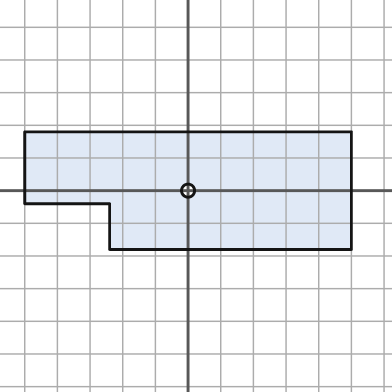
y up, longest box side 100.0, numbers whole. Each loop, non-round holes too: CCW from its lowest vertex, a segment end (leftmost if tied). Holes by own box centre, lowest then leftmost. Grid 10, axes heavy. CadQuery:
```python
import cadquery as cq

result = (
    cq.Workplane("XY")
    .moveTo(-24.0, -18.0)
    .lineTo(50.0, -18.0)
    .lineTo(50.0, 18.0)
    .lineTo(-50.0, 18.0)
    .lineTo(-50.0, -4.0)
    .lineTo(-24.0, -4.0)
    .close()
    .moveTo(0.0, 0.0)
    .circle(2.0)
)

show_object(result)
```